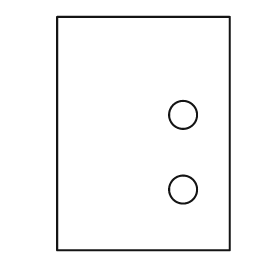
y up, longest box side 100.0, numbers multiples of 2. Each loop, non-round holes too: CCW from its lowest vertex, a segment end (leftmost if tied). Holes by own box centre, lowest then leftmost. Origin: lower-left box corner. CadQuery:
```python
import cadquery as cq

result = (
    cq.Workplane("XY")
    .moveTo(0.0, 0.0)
    .lineTo(74.0, 0.0)
    .lineTo(74.0, 100.0)
    .lineTo(0.0, 100.0)
    .close()
    .moveTo(54.0, 26.0)
    .circle(6.0)
    .moveTo(54.0, 58.0)
    .circle(6.0)
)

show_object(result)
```